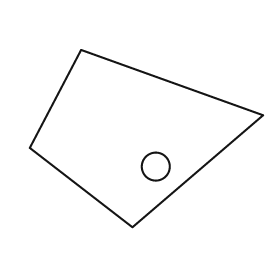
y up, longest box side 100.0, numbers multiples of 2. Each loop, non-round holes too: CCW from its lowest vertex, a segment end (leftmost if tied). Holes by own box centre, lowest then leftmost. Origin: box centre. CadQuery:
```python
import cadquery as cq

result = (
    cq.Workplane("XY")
    .moveTo(-6.0, -38.0)
    .lineTo(50.0, 10.0)
    .lineTo(-28.0, 38.0)
    .lineTo(-50.0, -4.0)
    .close()
    .moveTo(4.0, -12.0)
    .circle(6.0)
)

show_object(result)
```